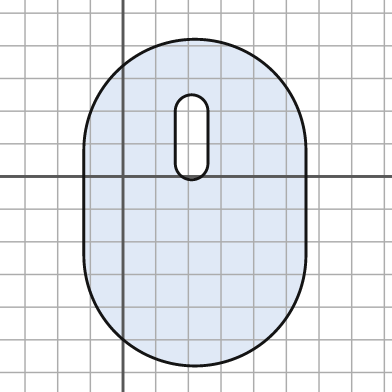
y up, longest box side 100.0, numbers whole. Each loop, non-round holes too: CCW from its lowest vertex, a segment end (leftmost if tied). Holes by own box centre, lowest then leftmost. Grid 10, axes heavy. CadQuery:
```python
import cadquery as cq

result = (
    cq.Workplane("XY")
    .moveTo(-12.0, -24.0)
    .threePointArc((22.0, -58.0), (56.0, -24.0))
    .lineTo(56.0, 8.0)
    .threePointArc((22.0, 42.0), (-12.0, 8.0))
    .close()
    .moveTo(16.0, 4.0)
    .threePointArc((21.0, -1.0), (26.0, 4.0))
    .lineTo(26.0, 20.0)
    .threePointArc((21.0, 25.0), (16.0, 20.0))
    .close()
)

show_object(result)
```